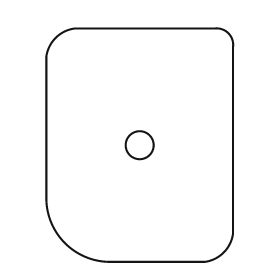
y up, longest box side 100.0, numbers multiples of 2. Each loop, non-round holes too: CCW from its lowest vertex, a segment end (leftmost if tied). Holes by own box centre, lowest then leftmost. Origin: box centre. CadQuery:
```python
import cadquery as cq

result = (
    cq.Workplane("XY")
    .moveTo(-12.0, -50.0)
    .lineTo(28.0, -50.0)
    .threePointArc((36.0, -46.0), (40.0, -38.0))
    .lineTo(40.0, 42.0)
    .threePointArc((38.0, 48.0), (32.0, 50.0))
    .lineTo(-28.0, 50.0)
    .threePointArc((-36.0, 46.0), (-40.0, 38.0))
    .lineTo(-40.0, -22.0)
    .threePointArc((-32.0, -42.0), (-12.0, -50.0))
    .close()
    .moveTo(0.0, 0.0)
    .circle(6.0)
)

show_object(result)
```